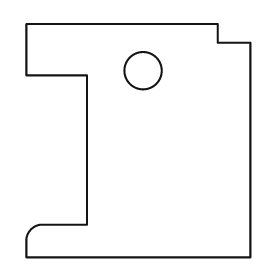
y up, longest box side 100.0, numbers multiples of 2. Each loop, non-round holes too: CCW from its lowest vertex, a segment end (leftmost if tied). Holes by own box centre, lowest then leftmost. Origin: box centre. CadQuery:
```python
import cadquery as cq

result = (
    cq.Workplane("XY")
    .moveTo(-48.0, -50.0)
    .lineTo(48.0, -50.0)
    .lineTo(48.0, 42.0)
    .lineTo(34.0, 42.0)
    .lineTo(34.0, 50.0)
    .lineTo(-48.0, 50.0)
    .lineTo(-48.0, 28.0)
    .lineTo(-22.0, 28.0)
    .lineTo(-22.0, -36.0)
    .lineTo(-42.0, -36.0)
    .threePointArc((-46.0, -38.0), (-48.0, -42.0))
    .close()
    .moveTo(2.0, 30.0)
    .circle(8.0)
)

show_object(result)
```